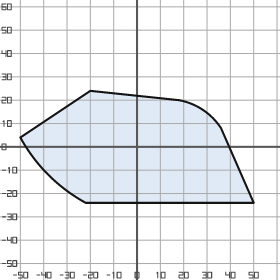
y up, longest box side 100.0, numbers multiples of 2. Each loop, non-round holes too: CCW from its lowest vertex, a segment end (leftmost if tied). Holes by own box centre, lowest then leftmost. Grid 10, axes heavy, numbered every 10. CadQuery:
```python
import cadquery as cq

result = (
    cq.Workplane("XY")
    .moveTo(-22.0, -24.0)
    .lineTo(50.0, -24.0)
    .lineTo(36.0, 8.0)
    .threePointArc((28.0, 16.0), (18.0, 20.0))
    .lineTo(-20.0, 24.0)
    .lineTo(-50.0, 4.0)
    .threePointArc((-38.0, -12.0), (-22.0, -24.0))
    .close()
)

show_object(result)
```